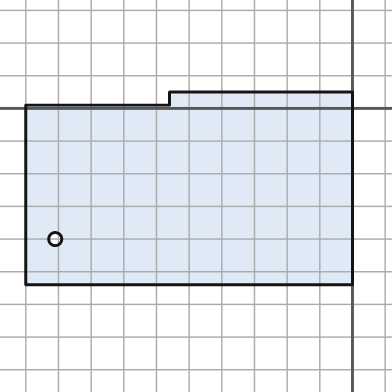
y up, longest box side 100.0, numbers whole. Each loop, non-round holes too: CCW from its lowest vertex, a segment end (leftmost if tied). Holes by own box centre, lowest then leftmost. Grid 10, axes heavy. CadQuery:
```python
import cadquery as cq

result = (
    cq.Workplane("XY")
    .moveTo(-100.0, -54.0)
    .lineTo(0.0, -54.0)
    .lineTo(0.0, 5.0)
    .lineTo(-56.0, 5.0)
    .lineTo(-56.0, 1.0)
    .lineTo(-100.0, 1.0)
    .close()
    .moveTo(-91.0, -40.0)
    .circle(2.0)
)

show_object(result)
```